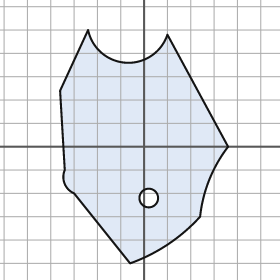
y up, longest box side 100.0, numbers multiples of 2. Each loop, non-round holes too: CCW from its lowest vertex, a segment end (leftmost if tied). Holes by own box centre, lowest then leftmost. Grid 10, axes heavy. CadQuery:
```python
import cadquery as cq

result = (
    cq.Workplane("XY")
    .moveTo(-6.0, -50.0)
    .threePointArc((10.0, -42.0), (24.0, -30.0))
    .threePointArc((28.0, -14.0), (36.0, 0.0))
    .lineTo(10.0, 48.0)
    .threePointArc((-8.0, 36.0), (-24.0, 50.0))
    .lineTo(-36.0, 24.0)
    .lineTo(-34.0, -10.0)
    .threePointArc((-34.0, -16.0), (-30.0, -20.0))
    .close()
    .moveTo(2.0, -22.0)
    .circle(4.0)
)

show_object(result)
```